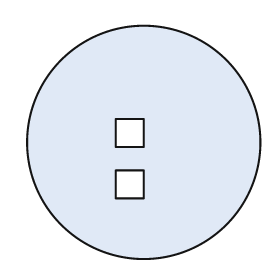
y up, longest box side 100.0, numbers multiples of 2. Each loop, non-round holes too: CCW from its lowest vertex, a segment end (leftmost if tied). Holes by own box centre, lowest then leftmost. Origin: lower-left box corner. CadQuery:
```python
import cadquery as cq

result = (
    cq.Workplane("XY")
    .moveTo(50.0, 50.0)
    .circle(50.0)
    .moveTo(38.0, 26.0)
    .lineTo(50.0, 26.0)
    .lineTo(50.0, 38.0)
    .lineTo(38.0, 38.0)
    .close()
    .moveTo(38.0, 48.0)
    .lineTo(50.0, 48.0)
    .lineTo(50.0, 60.0)
    .lineTo(38.0, 60.0)
    .close()
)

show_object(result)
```